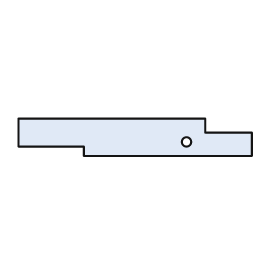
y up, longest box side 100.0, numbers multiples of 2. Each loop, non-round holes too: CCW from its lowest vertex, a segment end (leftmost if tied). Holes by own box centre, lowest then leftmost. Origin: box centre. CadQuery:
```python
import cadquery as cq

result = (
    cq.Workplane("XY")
    .moveTo(-22.0, -8.0)
    .lineTo(50.0, -8.0)
    .lineTo(50.0, 2.0)
    .lineTo(30.0, 2.0)
    .lineTo(30.0, 8.0)
    .lineTo(-50.0, 8.0)
    .lineTo(-50.0, -4.0)
    .lineTo(-22.0, -4.0)
    .close()
    .moveTo(22.0, -2.0)
    .circle(2.0)
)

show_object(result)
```